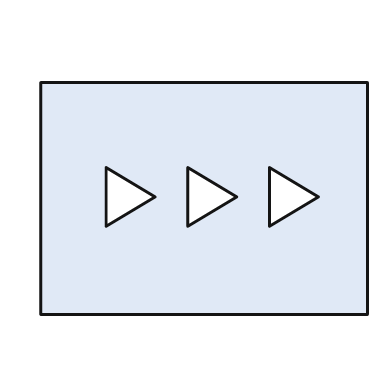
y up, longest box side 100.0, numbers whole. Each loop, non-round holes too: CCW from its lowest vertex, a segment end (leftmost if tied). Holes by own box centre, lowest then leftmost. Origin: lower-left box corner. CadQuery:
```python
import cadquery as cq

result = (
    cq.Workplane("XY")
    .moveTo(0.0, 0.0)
    .lineTo(100.0, 0.0)
    .lineTo(100.0, 71.0)
    .lineTo(0.0, 71.0)
    .close()
    .moveTo(20.0, 27.0)
    .lineTo(35.0, 36.0)
    .lineTo(20.0, 45.0)
    .close()
    .moveTo(45.0, 27.0)
    .lineTo(60.0, 36.0)
    .lineTo(45.0, 45.0)
    .close()
    .moveTo(70.0, 27.0)
    .lineTo(85.0, 36.0)
    .lineTo(70.0, 45.0)
    .close()
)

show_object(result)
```